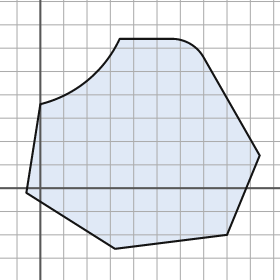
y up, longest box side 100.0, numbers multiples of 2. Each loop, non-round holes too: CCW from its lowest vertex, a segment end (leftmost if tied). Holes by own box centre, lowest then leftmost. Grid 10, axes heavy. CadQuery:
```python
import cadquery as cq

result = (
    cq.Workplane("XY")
    .moveTo(32.0, -26.0)
    .lineTo(80.0, -20.0)
    .lineTo(94.0, 14.0)
    .lineTo(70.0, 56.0)
    .threePointArc((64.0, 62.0), (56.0, 64.0))
    .lineTo(34.0, 64.0)
    .threePointArc((20.0, 46.0), (0.0, 36.0))
    .lineTo(-6.0, -2.0)
    .close()
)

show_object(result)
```